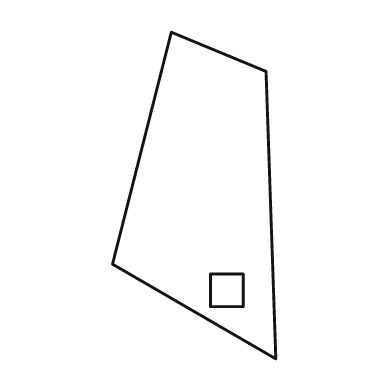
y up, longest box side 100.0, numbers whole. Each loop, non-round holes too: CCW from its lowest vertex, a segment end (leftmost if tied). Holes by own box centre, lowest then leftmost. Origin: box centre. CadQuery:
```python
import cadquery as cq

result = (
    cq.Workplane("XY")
    .moveTo(25.0, -50.0)
    .lineTo(22.0, 38.0)
    .lineTo(-7.0, 50.0)
    .lineTo(-25.0, -21.0)
    .close()
    .moveTo(5.0, -34.0)
    .lineTo(15.0, -34.0)
    .lineTo(15.0, -24.0)
    .lineTo(5.0, -24.0)
    .close()
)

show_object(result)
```